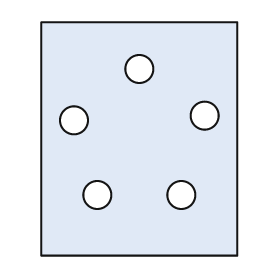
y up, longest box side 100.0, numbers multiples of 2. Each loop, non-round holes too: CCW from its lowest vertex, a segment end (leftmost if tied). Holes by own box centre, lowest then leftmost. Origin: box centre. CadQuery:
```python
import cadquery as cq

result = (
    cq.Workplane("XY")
    .moveTo(-42.0, -50.0)
    .lineTo(42.0, -50.0)
    .lineTo(42.0, 50.0)
    .lineTo(-42.0, 50.0)
    .close()
    .moveTo(-18.0, -24.0)
    .circle(6.0)
    .moveTo(18.0, -24.0)
    .circle(6.0)
    .moveTo(-28.0, 8.0)
    .circle(6.0)
    .moveTo(28.0, 10.0)
    .circle(6.0)
    .moveTo(0.0, 30.0)
    .circle(6.0)
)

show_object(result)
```